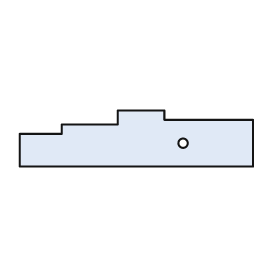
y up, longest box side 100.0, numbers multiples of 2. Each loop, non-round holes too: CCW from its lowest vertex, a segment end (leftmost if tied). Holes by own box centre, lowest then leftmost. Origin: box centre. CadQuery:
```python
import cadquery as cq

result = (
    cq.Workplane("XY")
    .moveTo(-50.0, -12.0)
    .lineTo(50.0, -12.0)
    .lineTo(50.0, 8.0)
    .lineTo(12.0, 8.0)
    .lineTo(12.0, 12.0)
    .lineTo(-8.0, 12.0)
    .lineTo(-8.0, 6.0)
    .lineTo(-32.0, 6.0)
    .lineTo(-32.0, 2.0)
    .lineTo(-50.0, 2.0)
    .close()
    .moveTo(20.0, -2.0)
    .circle(2.0)
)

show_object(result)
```